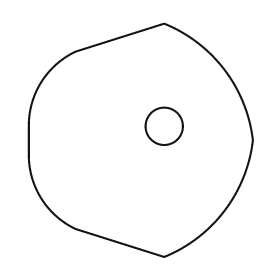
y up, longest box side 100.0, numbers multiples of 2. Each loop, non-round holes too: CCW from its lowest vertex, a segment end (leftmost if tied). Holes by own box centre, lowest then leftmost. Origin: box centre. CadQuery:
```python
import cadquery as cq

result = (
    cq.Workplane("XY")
    .moveTo(10.0, -50.0)
    .threePointArc((36.0, -30.0), (48.0, 0.0))
    .threePointArc((36.0, 30.0), (10.0, 50.0))
    .lineTo(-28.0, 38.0)
    .threePointArc((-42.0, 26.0), (-48.0, 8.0))
    .lineTo(-48.0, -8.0)
    .threePointArc((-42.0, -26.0), (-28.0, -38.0))
    .close()
    .moveTo(10.0, 6.0)
    .circle(8.0)
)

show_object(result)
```